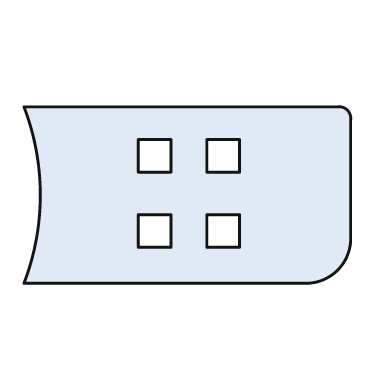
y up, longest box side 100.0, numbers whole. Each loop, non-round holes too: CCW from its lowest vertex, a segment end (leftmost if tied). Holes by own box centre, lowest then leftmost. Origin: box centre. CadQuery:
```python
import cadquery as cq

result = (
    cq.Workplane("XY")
    .moveTo(-50.0, -27.0)
    .lineTo(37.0, -27.0)
    .threePointArc((46.0, -23.0), (50.0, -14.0))
    .lineTo(50.0, 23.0)
    .threePointArc((49.0, 26.0), (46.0, 27.0))
    .lineTo(-50.0, 27.0)
    .threePointArc((-45.0, 0.0), (-50.0, -27.0))
    .close()
    .moveTo(-15.0, -16.0)
    .lineTo(-5.0, -16.0)
    .lineTo(-5.0, -6.0)
    .lineTo(-15.0, -6.0)
    .close()
    .moveTo(6.0, -16.0)
    .lineTo(16.0, -16.0)
    .lineTo(16.0, -6.0)
    .lineTo(6.0, -6.0)
    .close()
    .moveTo(-15.0, 7.0)
    .lineTo(-5.0, 7.0)
    .lineTo(-5.0, 17.0)
    .lineTo(-15.0, 17.0)
    .close()
    .moveTo(6.0, 7.0)
    .lineTo(16.0, 7.0)
    .lineTo(16.0, 17.0)
    .lineTo(6.0, 17.0)
    .close()
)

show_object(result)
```